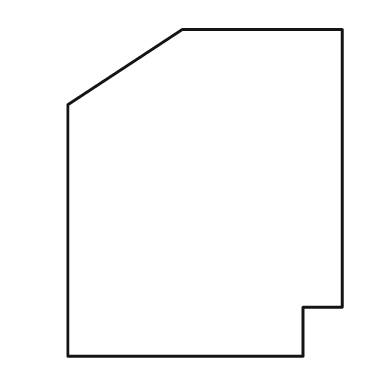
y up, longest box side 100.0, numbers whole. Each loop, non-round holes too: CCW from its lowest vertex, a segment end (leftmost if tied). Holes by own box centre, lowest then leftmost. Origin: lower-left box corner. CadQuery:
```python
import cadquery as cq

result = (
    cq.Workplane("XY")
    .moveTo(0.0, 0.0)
    .lineTo(72.0, 0.0)
    .lineTo(72.0, 15.0)
    .lineTo(84.0, 15.0)
    .lineTo(84.0, 100.0)
    .lineTo(35.0, 100.0)
    .lineTo(0.0, 77.0)
    .close()
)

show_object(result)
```